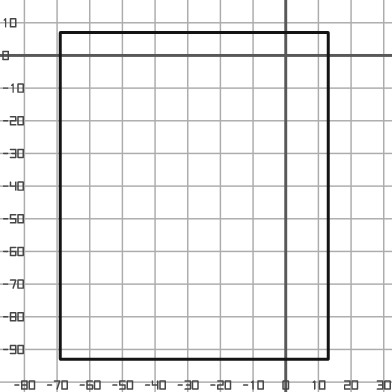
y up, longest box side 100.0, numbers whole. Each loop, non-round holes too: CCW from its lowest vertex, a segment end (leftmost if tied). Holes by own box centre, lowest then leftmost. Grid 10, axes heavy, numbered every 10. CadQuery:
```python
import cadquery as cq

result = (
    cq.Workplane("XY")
    .moveTo(-69.0, -93.0)
    .lineTo(13.0, -93.0)
    .lineTo(13.0, 7.0)
    .lineTo(-69.0, 7.0)
    .close()
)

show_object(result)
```